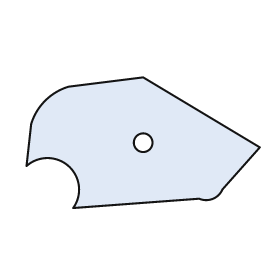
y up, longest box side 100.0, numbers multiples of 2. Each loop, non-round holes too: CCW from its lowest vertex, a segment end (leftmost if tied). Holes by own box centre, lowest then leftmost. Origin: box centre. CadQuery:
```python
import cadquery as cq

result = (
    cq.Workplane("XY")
    .moveTo(-30.0, -28.0)
    .lineTo(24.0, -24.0)
    .threePointArc((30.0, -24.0), (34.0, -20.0))
    .lineTo(50.0, -2.0)
    .lineTo(0.0, 28.0)
    .lineTo(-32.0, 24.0)
    .threePointArc((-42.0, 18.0), (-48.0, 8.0))
    .lineTo(-50.0, -10.0)
    .threePointArc((-32.0, -10.0), (-30.0, -28.0))
    .close()
    .moveTo(0.0, 0.0)
    .circle(4.0)
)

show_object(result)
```